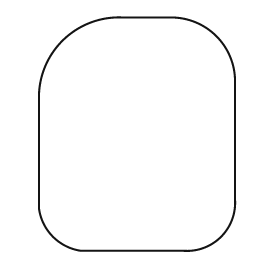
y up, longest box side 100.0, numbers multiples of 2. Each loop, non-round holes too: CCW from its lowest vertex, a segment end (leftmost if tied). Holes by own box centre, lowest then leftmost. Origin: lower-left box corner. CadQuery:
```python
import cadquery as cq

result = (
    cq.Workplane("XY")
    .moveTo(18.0, 0.0)
    .lineTo(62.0, 0.0)
    .threePointArc((78.0, 6.0), (84.0, 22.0))
    .lineTo(84.0, 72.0)
    .threePointArc((76.0, 92.0), (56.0, 100.0))
    .lineTo(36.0, 100.0)
    .threePointArc((10.0, 90.0), (0.0, 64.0))
    .lineTo(0.0, 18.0)
    .threePointArc((6.0, 6.0), (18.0, 0.0))
    .close()
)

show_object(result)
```